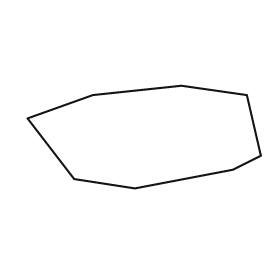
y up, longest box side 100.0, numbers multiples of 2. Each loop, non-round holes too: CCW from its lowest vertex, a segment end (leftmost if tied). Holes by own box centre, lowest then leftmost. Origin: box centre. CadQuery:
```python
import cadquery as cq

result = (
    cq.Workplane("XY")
    .moveTo(-4.0, -22.0)
    .lineTo(38.0, -14.0)
    .lineTo(50.0, -8.0)
    .lineTo(44.0, 18.0)
    .lineTo(16.0, 22.0)
    .lineTo(-22.0, 18.0)
    .lineTo(-50.0, 8.0)
    .lineTo(-30.0, -18.0)
    .close()
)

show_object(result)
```